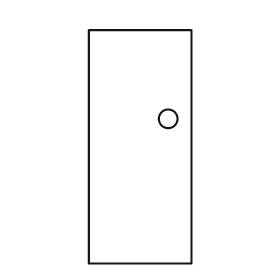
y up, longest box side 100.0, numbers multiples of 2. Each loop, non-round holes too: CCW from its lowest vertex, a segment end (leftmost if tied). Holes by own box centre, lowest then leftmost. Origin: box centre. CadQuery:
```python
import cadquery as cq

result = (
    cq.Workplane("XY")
    .moveTo(-22.0, -50.0)
    .lineTo(22.0, -50.0)
    .lineTo(22.0, 50.0)
    .lineTo(-22.0, 50.0)
    .close()
    .moveTo(12.0, 12.0)
    .circle(4.0)
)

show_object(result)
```